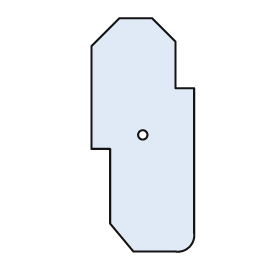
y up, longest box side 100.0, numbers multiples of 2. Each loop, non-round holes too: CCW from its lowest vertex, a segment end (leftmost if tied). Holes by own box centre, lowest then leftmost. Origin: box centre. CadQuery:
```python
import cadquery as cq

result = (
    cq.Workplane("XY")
    .moveTo(-4.0, -50.0)
    .lineTo(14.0, -50.0)
    .threePointArc((20.0, -48.0), (22.0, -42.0))
    .lineTo(22.0, 20.0)
    .lineTo(14.0, 20.0)
    .lineTo(14.0, 40.0)
    .lineTo(4.0, 50.0)
    .lineTo(-10.0, 50.0)
    .lineTo(-22.0, 38.0)
    .lineTo(-22.0, -6.0)
    .lineTo(-14.0, -6.0)
    .lineTo(-14.0, -38.0)
    .close()
    .moveTo(0.0, 0.0)
    .circle(2.0)
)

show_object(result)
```